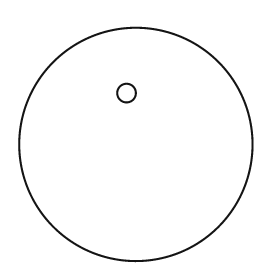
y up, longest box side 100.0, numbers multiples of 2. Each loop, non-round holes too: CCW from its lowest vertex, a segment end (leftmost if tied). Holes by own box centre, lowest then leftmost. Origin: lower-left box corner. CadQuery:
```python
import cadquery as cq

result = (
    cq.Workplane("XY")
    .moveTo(50.0, 50.0)
    .circle(50.0)
    .moveTo(46.0, 72.0)
    .circle(4.0)
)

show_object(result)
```